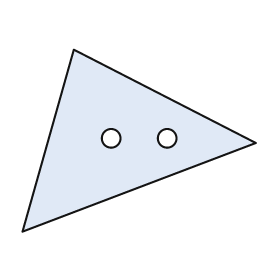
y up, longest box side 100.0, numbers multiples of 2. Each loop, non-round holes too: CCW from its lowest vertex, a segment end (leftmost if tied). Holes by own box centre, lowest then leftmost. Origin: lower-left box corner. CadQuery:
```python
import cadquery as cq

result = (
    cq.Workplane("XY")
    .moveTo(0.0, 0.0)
    .lineTo(100.0, 38.0)
    .lineTo(22.0, 78.0)
    .close()
    .moveTo(38.0, 40.0)
    .circle(4.0)
    .moveTo(62.0, 40.0)
    .circle(4.0)
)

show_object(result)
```